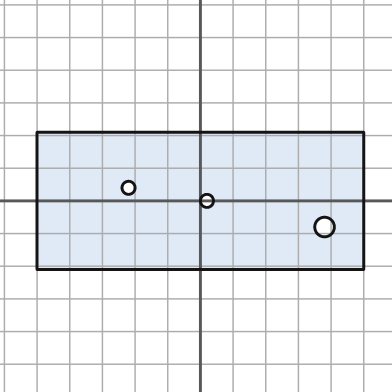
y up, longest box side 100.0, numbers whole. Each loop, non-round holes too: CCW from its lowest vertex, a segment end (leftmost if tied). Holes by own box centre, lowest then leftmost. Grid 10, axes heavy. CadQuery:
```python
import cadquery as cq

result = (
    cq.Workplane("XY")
    .moveTo(-50.0, -21.0)
    .lineTo(50.0, -21.0)
    .lineTo(50.0, 21.0)
    .lineTo(-50.0, 21.0)
    .close()
    .moveTo(38.0, -8.0)
    .circle(3.0)
    .moveTo(2.0, 0.0)
    .circle(2.0)
    .moveTo(-22.0, 4.0)
    .circle(2.0)
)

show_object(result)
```